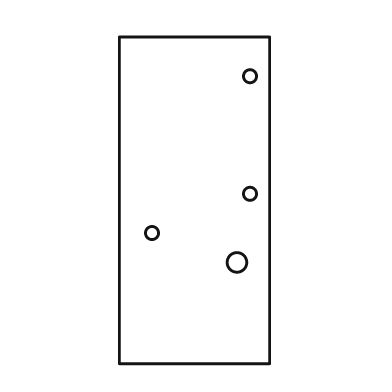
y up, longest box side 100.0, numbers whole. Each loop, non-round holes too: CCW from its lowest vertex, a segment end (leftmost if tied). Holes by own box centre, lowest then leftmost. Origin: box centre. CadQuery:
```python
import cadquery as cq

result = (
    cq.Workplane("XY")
    .moveTo(-23.0, -50.0)
    .lineTo(23.0, -50.0)
    .lineTo(23.0, 50.0)
    .lineTo(-23.0, 50.0)
    .close()
    .moveTo(13.0, -19.0)
    .circle(3.0)
    .moveTo(-13.0, -10.0)
    .circle(2.0)
    .moveTo(17.0, 2.0)
    .circle(2.0)
    .moveTo(17.0, 38.0)
    .circle(2.0)
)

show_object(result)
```